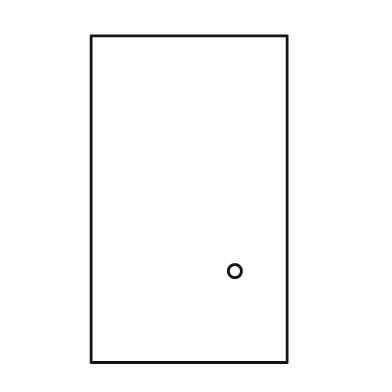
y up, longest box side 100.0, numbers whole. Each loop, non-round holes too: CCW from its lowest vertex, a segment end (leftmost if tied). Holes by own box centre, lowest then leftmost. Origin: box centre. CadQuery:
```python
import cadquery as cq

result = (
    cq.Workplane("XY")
    .moveTo(-30.0, -50.0)
    .lineTo(30.0, -50.0)
    .lineTo(30.0, 50.0)
    .lineTo(-30.0, 50.0)
    .close()
    .moveTo(14.0, -22.0)
    .circle(2.0)
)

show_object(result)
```